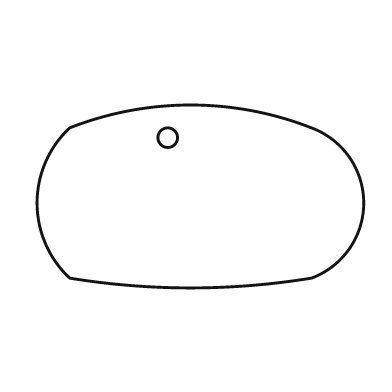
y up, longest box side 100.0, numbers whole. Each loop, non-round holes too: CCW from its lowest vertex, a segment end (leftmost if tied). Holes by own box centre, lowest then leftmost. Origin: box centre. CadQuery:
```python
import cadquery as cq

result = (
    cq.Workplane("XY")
    .moveTo(-40.0, -25.0)
    .threePointArc((-3.0, -28.0), (34.0, -25.0))
    .threePointArc((50.0, -2.0), (34.0, 21.0))
    .threePointArc((-3.0, 28.0), (-40.0, 21.0))
    .threePointArc((-50.0, -2.0), (-40.0, -25.0))
    .close()
    .moveTo(-10.0, 18.0)
    .circle(3.0)
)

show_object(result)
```